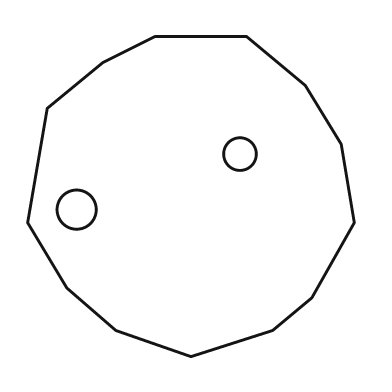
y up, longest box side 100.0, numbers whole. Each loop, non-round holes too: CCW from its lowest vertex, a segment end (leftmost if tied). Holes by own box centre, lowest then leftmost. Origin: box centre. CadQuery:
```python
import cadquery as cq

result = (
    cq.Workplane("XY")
    .moveTo(0.0, -49.0)
    .lineTo(25.0, -41.0)
    .lineTo(37.0, -31.0)
    .lineTo(50.0, -8.0)
    .lineTo(46.0, 16.0)
    .lineTo(35.0, 34.0)
    .lineTo(17.0, 49.0)
    .lineTo(-11.0, 49.0)
    .lineTo(-27.0, 41.0)
    .lineTo(-44.0, 27.0)
    .lineTo(-50.0, -8.0)
    .lineTo(-38.0, -28.0)
    .lineTo(-23.0, -41.0)
    .close()
    .moveTo(-35.0, -4.0)
    .circle(6.0)
    .moveTo(15.0, 13.0)
    .circle(5.0)
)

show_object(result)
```